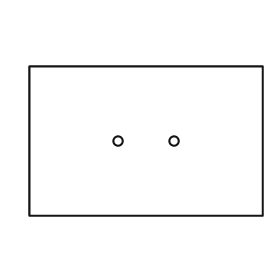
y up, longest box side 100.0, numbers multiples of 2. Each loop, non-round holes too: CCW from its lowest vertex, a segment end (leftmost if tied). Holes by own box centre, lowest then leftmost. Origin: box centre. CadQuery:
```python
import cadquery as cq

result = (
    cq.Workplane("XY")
    .moveTo(-50.0, -32.0)
    .lineTo(50.0, -32.0)
    .lineTo(50.0, 32.0)
    .lineTo(-50.0, 32.0)
    .close()
    .moveTo(-12.0, 0.0)
    .circle(2.0)
    .moveTo(12.0, 0.0)
    .circle(2.0)
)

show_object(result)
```